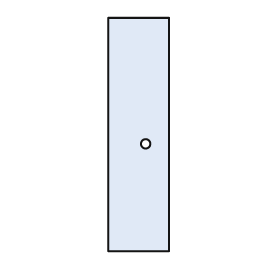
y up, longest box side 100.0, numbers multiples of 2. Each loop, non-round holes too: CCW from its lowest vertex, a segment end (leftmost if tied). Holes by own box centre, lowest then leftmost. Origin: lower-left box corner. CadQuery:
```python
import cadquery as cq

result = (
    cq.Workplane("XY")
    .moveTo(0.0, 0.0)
    .lineTo(26.0, 0.0)
    .lineTo(26.0, 100.0)
    .lineTo(0.0, 100.0)
    .close()
    .moveTo(16.0, 46.0)
    .circle(2.0)
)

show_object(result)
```